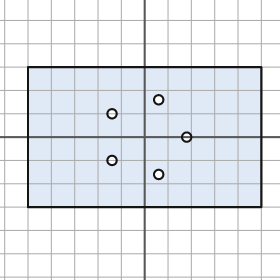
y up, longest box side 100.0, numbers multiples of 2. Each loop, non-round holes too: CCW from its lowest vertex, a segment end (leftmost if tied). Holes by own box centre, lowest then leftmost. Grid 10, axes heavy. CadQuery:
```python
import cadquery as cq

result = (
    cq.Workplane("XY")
    .moveTo(-50.0, -30.0)
    .lineTo(50.0, -30.0)
    .lineTo(50.0, 30.0)
    .lineTo(-50.0, 30.0)
    .close()
    .moveTo(6.0, -16.0)
    .circle(2.0)
    .moveTo(-14.0, -10.0)
    .circle(2.0)
    .moveTo(18.0, 0.0)
    .circle(2.0)
    .moveTo(-14.0, 10.0)
    .circle(2.0)
    .moveTo(6.0, 16.0)
    .circle(2.0)
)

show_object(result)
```